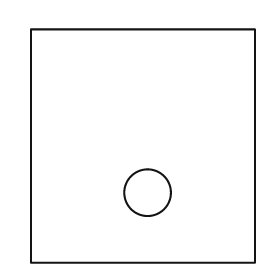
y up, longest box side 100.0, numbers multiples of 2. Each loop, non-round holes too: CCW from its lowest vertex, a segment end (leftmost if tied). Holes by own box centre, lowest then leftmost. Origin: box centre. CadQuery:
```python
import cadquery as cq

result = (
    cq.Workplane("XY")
    .moveTo(-48.0, -50.0)
    .lineTo(48.0, -50.0)
    .lineTo(48.0, 50.0)
    .lineTo(-48.0, 50.0)
    .close()
    .moveTo(2.0, -20.0)
    .circle(10.0)
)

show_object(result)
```